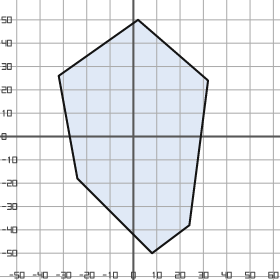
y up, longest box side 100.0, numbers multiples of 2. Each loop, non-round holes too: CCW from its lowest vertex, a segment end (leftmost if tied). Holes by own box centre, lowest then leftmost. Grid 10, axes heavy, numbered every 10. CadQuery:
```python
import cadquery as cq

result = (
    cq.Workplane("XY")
    .moveTo(8.0, -50.0)
    .lineTo(24.0, -38.0)
    .lineTo(32.0, 24.0)
    .lineTo(2.0, 50.0)
    .lineTo(-32.0, 26.0)
    .lineTo(-24.0, -18.0)
    .close()
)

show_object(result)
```